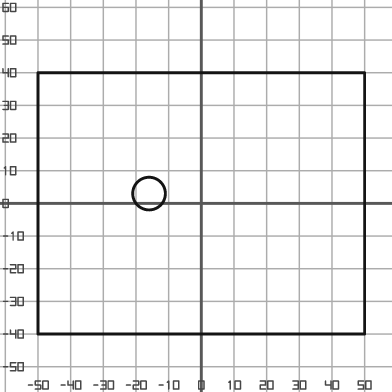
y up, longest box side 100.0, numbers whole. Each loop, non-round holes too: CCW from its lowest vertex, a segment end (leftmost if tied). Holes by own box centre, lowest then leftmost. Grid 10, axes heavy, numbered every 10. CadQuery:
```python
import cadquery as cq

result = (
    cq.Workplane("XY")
    .moveTo(-50.0, -40.0)
    .lineTo(50.0, -40.0)
    .lineTo(50.0, 40.0)
    .lineTo(-50.0, 40.0)
    .close()
    .moveTo(-16.0, 3.0)
    .circle(5.0)
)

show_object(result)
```